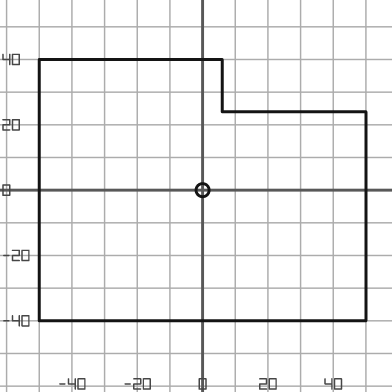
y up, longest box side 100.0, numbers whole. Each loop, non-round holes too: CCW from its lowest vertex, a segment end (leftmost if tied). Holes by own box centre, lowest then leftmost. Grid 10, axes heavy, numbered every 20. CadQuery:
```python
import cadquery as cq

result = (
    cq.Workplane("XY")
    .moveTo(-50.0, -40.0)
    .lineTo(50.0, -40.0)
    .lineTo(50.0, 24.0)
    .lineTo(6.0, 24.0)
    .lineTo(6.0, 40.0)
    .lineTo(-50.0, 40.0)
    .close()
    .moveTo(0.0, 0.0)
    .circle(2.0)
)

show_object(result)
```